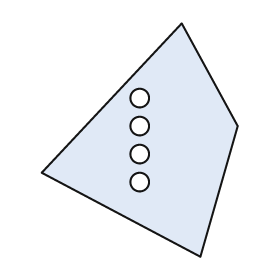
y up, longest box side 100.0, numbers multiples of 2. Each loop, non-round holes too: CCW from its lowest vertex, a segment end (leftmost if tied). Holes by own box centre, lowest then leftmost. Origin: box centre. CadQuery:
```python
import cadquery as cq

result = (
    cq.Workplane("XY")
    .moveTo(26.0, -50.0)
    .lineTo(42.0, 6.0)
    .lineTo(18.0, 50.0)
    .lineTo(-42.0, -14.0)
    .close()
    .moveTo(0.0, -18.0)
    .circle(4.0)
    .moveTo(0.0, -6.0)
    .circle(4.0)
    .moveTo(0.0, 6.0)
    .circle(4.0)
    .moveTo(0.0, 18.0)
    .circle(4.0)
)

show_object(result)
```